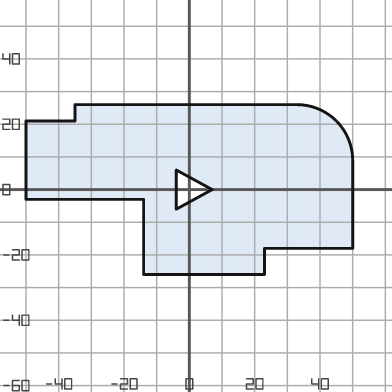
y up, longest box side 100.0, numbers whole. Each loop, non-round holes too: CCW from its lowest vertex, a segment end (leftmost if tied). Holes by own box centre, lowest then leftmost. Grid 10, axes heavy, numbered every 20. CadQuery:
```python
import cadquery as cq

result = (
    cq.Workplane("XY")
    .moveTo(-14.0, -26.0)
    .lineTo(23.0, -26.0)
    .lineTo(23.0, -18.0)
    .lineTo(50.0, -18.0)
    .lineTo(50.0, 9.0)
    .threePointArc((45.0, 21.0), (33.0, 26.0))
    .lineTo(-35.0, 26.0)
    .lineTo(-35.0, 21.0)
    .lineTo(-50.0, 21.0)
    .lineTo(-50.0, -3.0)
    .lineTo(-14.0, -3.0)
    .close()
    .moveTo(-4.0, -6.0)
    .lineTo(7.0, 0.0)
    .lineTo(-4.0, 6.0)
    .close()
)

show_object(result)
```